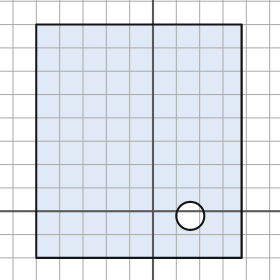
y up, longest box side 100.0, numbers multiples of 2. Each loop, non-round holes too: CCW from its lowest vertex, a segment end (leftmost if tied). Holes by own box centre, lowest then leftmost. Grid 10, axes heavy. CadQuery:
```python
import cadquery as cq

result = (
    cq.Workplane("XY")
    .moveTo(-50.0, -20.0)
    .lineTo(38.0, -20.0)
    .lineTo(38.0, 80.0)
    .lineTo(-50.0, 80.0)
    .close()
    .moveTo(16.0, -2.0)
    .circle(6.0)
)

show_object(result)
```